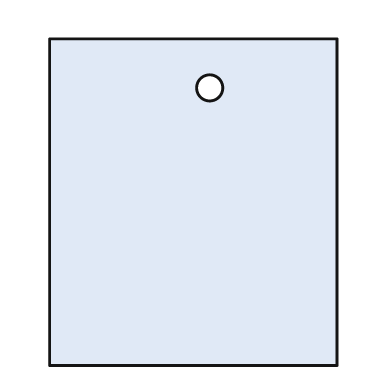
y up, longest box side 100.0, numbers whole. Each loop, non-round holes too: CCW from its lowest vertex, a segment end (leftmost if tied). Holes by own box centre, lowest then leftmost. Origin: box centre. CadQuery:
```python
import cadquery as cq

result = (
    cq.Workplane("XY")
    .moveTo(-44.0, -50.0)
    .lineTo(44.0, -50.0)
    .lineTo(44.0, 50.0)
    .lineTo(-44.0, 50.0)
    .close()
    .moveTo(5.0, 35.0)
    .circle(4.0)
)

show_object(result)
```